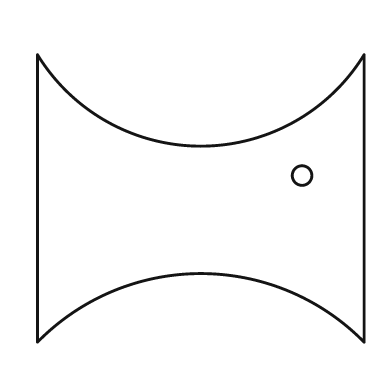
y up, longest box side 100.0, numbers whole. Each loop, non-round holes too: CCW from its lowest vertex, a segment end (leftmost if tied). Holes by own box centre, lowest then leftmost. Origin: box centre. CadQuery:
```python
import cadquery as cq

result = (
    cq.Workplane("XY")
    .moveTo(-50.0, -44.0)
    .threePointArc((0.0, -23.0), (50.0, -44.0))
    .lineTo(50.0, 44.0)
    .threePointArc((0.0, 16.0), (-50.0, 44.0))
    .close()
    .moveTo(31.0, 7.0)
    .circle(3.0)
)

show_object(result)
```